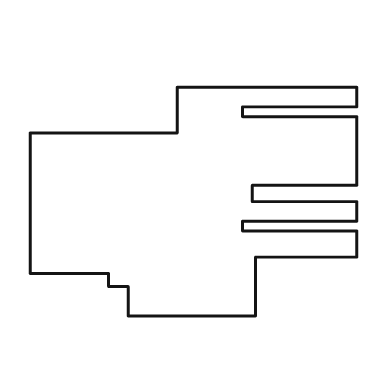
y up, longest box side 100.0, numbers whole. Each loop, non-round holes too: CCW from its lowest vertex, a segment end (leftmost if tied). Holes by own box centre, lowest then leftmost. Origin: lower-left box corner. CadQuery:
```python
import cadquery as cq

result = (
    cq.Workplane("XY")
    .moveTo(30.0, 0.0)
    .lineTo(69.0, 0.0)
    .lineTo(69.0, 18.0)
    .lineTo(100.0, 18.0)
    .lineTo(100.0, 26.0)
    .lineTo(65.0, 26.0)
    .lineTo(65.0, 29.0)
    .lineTo(100.0, 29.0)
    .lineTo(100.0, 35.0)
    .lineTo(68.0, 35.0)
    .lineTo(68.0, 40.0)
    .lineTo(100.0, 40.0)
    .lineTo(100.0, 61.0)
    .lineTo(65.0, 61.0)
    .lineTo(65.0, 64.0)
    .lineTo(100.0, 64.0)
    .lineTo(100.0, 70.0)
    .lineTo(45.0, 70.0)
    .lineTo(45.0, 56.0)
    .lineTo(0.0, 56.0)
    .lineTo(0.0, 13.0)
    .lineTo(24.0, 13.0)
    .lineTo(24.0, 9.0)
    .lineTo(30.0, 9.0)
    .close()
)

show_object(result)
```